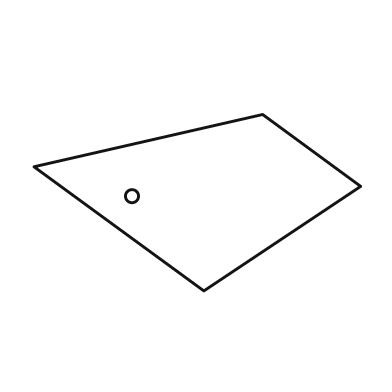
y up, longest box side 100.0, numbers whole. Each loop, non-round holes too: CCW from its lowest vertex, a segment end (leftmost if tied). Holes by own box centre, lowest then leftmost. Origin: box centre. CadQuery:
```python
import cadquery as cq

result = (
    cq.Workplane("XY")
    .moveTo(2.0, -27.0)
    .lineTo(50.0, 5.0)
    .lineTo(20.0, 27.0)
    .lineTo(-50.0, 11.0)
    .close()
    .moveTo(-20.0, 2.0)
    .circle(2.0)
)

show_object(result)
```